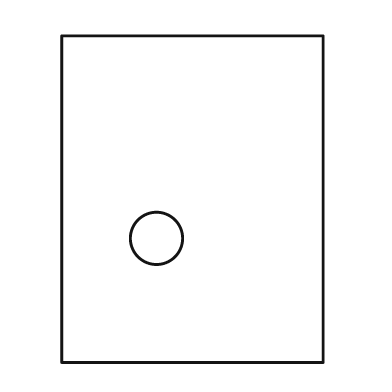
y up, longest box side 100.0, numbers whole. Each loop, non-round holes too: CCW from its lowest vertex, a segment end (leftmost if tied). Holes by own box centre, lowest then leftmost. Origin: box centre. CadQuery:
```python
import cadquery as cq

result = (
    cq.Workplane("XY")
    .moveTo(-40.0, -50.0)
    .lineTo(40.0, -50.0)
    .lineTo(40.0, 50.0)
    .lineTo(-40.0, 50.0)
    .close()
    .moveTo(-11.0, -12.0)
    .circle(8.0)
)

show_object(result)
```